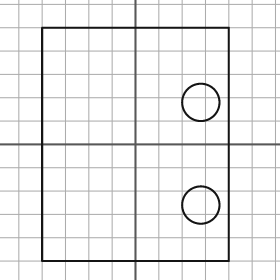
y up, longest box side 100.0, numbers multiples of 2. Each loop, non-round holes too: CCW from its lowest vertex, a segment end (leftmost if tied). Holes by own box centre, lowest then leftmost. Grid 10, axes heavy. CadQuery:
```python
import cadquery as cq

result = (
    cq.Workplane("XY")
    .moveTo(-40.0, -50.0)
    .lineTo(40.0, -50.0)
    .lineTo(40.0, 50.0)
    .lineTo(-40.0, 50.0)
    .close()
    .moveTo(28.0, -26.0)
    .circle(8.0)
    .moveTo(28.0, 18.0)
    .circle(8.0)
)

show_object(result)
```